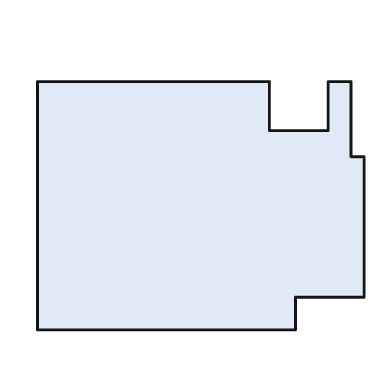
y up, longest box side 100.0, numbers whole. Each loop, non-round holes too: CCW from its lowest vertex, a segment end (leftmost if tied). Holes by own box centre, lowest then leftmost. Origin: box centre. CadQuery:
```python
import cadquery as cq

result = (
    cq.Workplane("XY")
    .moveTo(-50.0, -38.0)
    .lineTo(29.0, -38.0)
    .lineTo(29.0, -28.0)
    .lineTo(50.0, -28.0)
    .lineTo(50.0, 15.0)
    .lineTo(46.0, 15.0)
    .lineTo(46.0, 38.0)
    .lineTo(39.0, 38.0)
    .lineTo(39.0, 23.0)
    .lineTo(21.0, 23.0)
    .lineTo(21.0, 38.0)
    .lineTo(-50.0, 38.0)
    .close()
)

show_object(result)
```